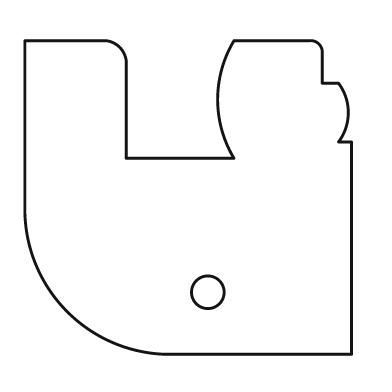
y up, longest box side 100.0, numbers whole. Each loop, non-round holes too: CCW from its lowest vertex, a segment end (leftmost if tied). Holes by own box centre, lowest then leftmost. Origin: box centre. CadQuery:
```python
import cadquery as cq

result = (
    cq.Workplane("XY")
    .moveTo(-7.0, -48.0)
    .lineTo(50.0, -48.0)
    .lineTo(50.0, 17.0)
    .lineTo(46.0, 17.0)
    .threePointArc((49.0, 26.0), (46.0, 35.0))
    .lineTo(41.0, 35.0)
    .lineTo(41.0, 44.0)
    .threePointArc((40.0, 47.0), (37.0, 48.0))
    .lineTo(14.0, 48.0)
    .threePointArc((9.0, 30.0), (14.0, 12.0))
    .lineTo(-19.0, 12.0)
    .lineTo(-19.0, 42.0)
    .threePointArc((-21.0, 46.0), (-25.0, 48.0))
    .lineTo(-50.0, 48.0)
    .lineTo(-50.0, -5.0)
    .threePointArc((-37.0, -35.0), (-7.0, -48.0))
    .close()
    .moveTo(6.0, -29.0)
    .circle(5.0)
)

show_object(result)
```